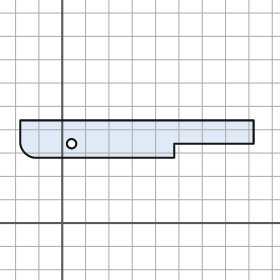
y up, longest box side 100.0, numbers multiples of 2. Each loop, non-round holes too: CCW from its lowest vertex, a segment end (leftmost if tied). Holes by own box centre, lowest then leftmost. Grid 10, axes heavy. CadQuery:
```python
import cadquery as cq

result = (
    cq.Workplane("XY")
    .moveTo(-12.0, 28.0)
    .lineTo(48.0, 28.0)
    .lineTo(48.0, 34.0)
    .lineTo(82.0, 34.0)
    .lineTo(82.0, 44.0)
    .lineTo(-18.0, 44.0)
    .lineTo(-18.0, 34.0)
    .threePointArc((-16.0, 30.0), (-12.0, 28.0))
    .close()
    .moveTo(4.0, 34.0)
    .circle(2.0)
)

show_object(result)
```